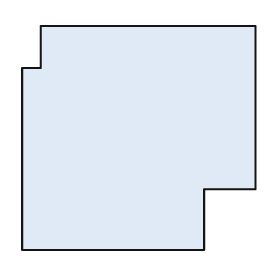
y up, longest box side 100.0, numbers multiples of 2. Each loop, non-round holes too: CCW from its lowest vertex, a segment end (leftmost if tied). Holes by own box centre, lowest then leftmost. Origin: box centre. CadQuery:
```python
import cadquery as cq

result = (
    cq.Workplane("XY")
    .moveTo(-50.0, -48.0)
    .lineTo(28.0, -48.0)
    .lineTo(28.0, -22.0)
    .lineTo(50.0, -22.0)
    .lineTo(50.0, 48.0)
    .lineTo(-42.0, 48.0)
    .lineTo(-42.0, 30.0)
    .lineTo(-50.0, 30.0)
    .close()
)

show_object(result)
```